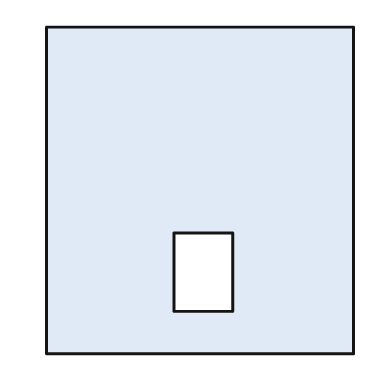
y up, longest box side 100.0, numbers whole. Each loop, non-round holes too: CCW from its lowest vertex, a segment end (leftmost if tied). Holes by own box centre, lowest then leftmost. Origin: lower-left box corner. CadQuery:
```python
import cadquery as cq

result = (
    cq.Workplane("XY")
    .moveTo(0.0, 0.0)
    .lineTo(94.0, 0.0)
    .lineTo(94.0, 100.0)
    .lineTo(0.0, 100.0)
    .close()
    .moveTo(39.0, 13.0)
    .lineTo(57.0, 13.0)
    .lineTo(57.0, 37.0)
    .lineTo(39.0, 37.0)
    .close()
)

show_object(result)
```